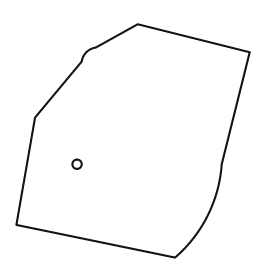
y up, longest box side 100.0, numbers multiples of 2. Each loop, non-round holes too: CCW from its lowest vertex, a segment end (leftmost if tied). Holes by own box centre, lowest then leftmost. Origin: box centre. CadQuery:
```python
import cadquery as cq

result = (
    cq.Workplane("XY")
    .moveTo(18.0, -50.0)
    .threePointArc((32.0, -32.0), (38.0, -10.0))
    .lineTo(50.0, 38.0)
    .lineTo(2.0, 50.0)
    .lineTo(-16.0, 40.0)
    .threePointArc((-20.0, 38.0), (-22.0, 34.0))
    .lineTo(-42.0, 10.0)
    .lineTo(-50.0, -36.0)
    .close()
    .moveTo(-24.0, -10.0)
    .circle(2.0)
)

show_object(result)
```